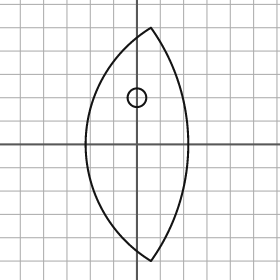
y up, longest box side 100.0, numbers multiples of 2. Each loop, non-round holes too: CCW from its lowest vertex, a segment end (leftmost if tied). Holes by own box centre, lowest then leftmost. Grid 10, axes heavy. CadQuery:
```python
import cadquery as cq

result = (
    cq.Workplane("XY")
    .moveTo(6.0, -50.0)
    .threePointArc((22.0, 0.0), (6.0, 50.0))
    .threePointArc((-22.0, 0.0), (6.0, -50.0))
    .close()
    .moveTo(0.0, 20.0)
    .circle(4.0)
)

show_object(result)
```